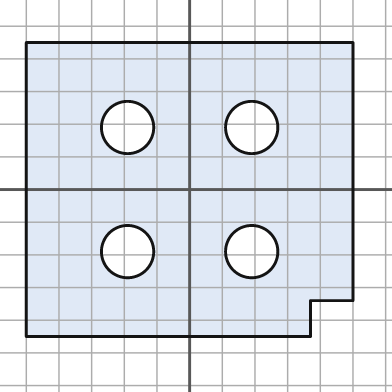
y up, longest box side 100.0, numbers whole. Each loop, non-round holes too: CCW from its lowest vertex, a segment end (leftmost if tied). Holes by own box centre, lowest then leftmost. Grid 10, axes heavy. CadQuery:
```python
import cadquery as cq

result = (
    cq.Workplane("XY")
    .moveTo(-50.0, -45.0)
    .lineTo(37.0, -45.0)
    .lineTo(37.0, -34.0)
    .lineTo(50.0, -34.0)
    .lineTo(50.0, 45.0)
    .lineTo(-50.0, 45.0)
    .close()
    .moveTo(-19.0, -19.0)
    .circle(8.0)
    .moveTo(19.0, -19.0)
    .circle(8.0)
    .moveTo(-19.0, 19.0)
    .circle(8.0)
    .moveTo(19.0, 19.0)
    .circle(8.0)
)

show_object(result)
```